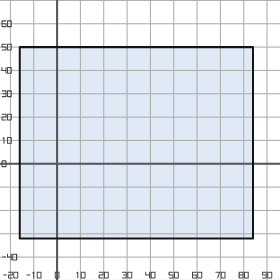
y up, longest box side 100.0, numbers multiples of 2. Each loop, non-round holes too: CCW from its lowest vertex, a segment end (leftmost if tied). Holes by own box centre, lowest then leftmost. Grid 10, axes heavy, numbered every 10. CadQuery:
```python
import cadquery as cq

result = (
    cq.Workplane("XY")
    .moveTo(-16.0, -32.0)
    .lineTo(84.0, -32.0)
    .lineTo(84.0, 50.0)
    .lineTo(-16.0, 50.0)
    .close()
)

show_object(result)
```